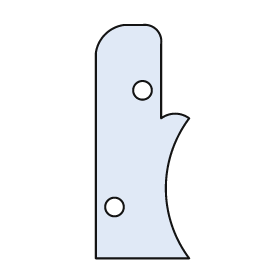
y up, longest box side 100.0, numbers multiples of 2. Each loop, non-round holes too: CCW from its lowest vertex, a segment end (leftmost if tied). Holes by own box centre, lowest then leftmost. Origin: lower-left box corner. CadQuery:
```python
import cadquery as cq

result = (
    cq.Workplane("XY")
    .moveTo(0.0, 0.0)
    .lineTo(40.0, 0.0)
    .threePointArc((30.0, 30.0), (40.0, 60.0))
    .threePointArc((34.0, 62.0), (28.0, 60.0))
    .lineTo(28.0, 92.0)
    .threePointArc((26.0, 98.0), (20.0, 100.0))
    .lineTo(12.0, 100.0)
    .threePointArc((4.0, 96.0), (0.0, 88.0))
    .close()
    .moveTo(8.0, 22.0)
    .circle(4.0)
    .moveTo(20.0, 72.0)
    .circle(4.0)
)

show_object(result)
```